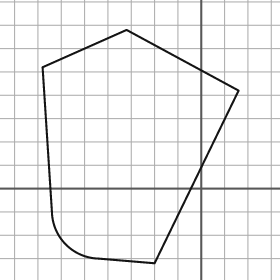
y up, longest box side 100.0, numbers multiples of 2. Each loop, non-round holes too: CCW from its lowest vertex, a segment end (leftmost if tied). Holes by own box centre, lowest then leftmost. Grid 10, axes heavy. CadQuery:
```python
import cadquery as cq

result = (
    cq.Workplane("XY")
    .moveTo(-20.0, -32.0)
    .lineTo(16.0, 42.0)
    .lineTo(-32.0, 68.0)
    .lineTo(-68.0, 52.0)
    .lineTo(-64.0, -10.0)
    .threePointArc((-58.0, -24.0), (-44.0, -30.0))
    .close()
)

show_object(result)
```